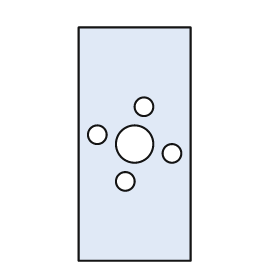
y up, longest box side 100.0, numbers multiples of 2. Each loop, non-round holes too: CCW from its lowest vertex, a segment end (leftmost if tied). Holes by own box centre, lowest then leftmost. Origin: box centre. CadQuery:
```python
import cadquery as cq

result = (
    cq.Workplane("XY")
    .moveTo(-24.0, -50.0)
    .lineTo(24.0, -50.0)
    .lineTo(24.0, 50.0)
    .lineTo(-24.0, 50.0)
    .close()
    .moveTo(-4.0, -16.0)
    .circle(4.0)
    .moveTo(16.0, -4.0)
    .circle(4.0)
    .moveTo(0.0, 0.0)
    .circle(8.0)
    .moveTo(-16.0, 4.0)
    .circle(4.0)
    .moveTo(4.0, 16.0)
    .circle(4.0)
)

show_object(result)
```